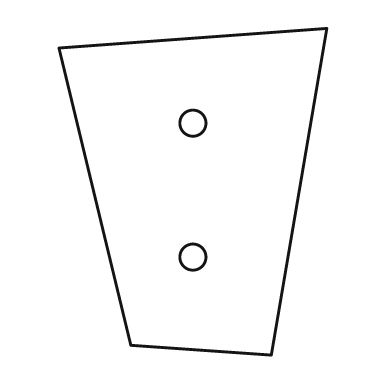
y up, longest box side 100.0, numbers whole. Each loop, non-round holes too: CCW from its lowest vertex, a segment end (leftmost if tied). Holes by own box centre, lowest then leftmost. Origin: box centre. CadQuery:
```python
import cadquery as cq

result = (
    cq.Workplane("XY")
    .moveTo(24.0, -50.0)
    .lineTo(41.0, 50.0)
    .lineTo(-41.0, 44.0)
    .lineTo(-19.0, -47.0)
    .close()
    .moveTo(0.0, -20.0)
    .circle(4.0)
    .moveTo(0.0, 21.0)
    .circle(4.0)
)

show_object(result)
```